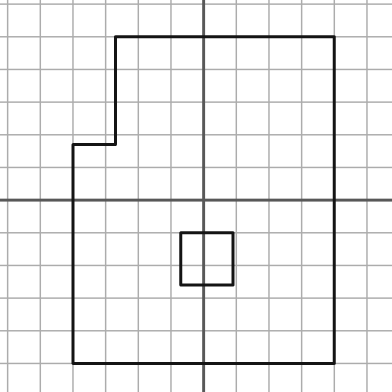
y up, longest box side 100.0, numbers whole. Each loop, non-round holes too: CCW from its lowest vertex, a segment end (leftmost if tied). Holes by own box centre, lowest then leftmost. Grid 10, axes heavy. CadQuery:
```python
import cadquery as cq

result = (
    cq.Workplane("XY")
    .moveTo(-40.0, -50.0)
    .lineTo(40.0, -50.0)
    .lineTo(40.0, 50.0)
    .lineTo(-27.0, 50.0)
    .lineTo(-27.0, 17.0)
    .lineTo(-40.0, 17.0)
    .close()
    .moveTo(-7.0, -26.0)
    .lineTo(9.0, -26.0)
    .lineTo(9.0, -10.0)
    .lineTo(-7.0, -10.0)
    .close()
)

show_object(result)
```